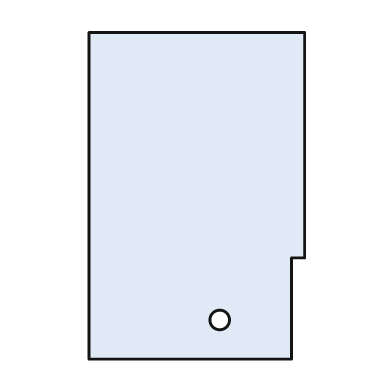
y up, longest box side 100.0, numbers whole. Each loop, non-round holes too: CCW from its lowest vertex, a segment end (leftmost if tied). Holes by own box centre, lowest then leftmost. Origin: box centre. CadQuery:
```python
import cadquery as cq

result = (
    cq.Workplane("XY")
    .moveTo(-33.0, -50.0)
    .lineTo(29.0, -50.0)
    .lineTo(29.0, -19.0)
    .lineTo(33.0, -19.0)
    .lineTo(33.0, 50.0)
    .lineTo(-33.0, 50.0)
    .close()
    .moveTo(7.0, -38.0)
    .circle(3.0)
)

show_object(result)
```